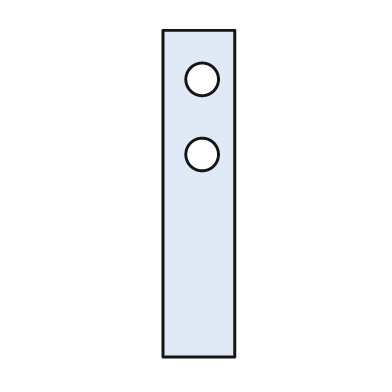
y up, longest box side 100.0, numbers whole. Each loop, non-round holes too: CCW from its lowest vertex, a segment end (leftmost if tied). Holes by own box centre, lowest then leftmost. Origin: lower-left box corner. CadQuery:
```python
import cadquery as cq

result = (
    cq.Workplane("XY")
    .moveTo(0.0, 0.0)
    .lineTo(22.0, 0.0)
    .lineTo(22.0, 100.0)
    .lineTo(0.0, 100.0)
    .close()
    .moveTo(12.0, 62.0)
    .circle(5.0)
    .moveTo(12.0, 85.0)
    .circle(5.0)
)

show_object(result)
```